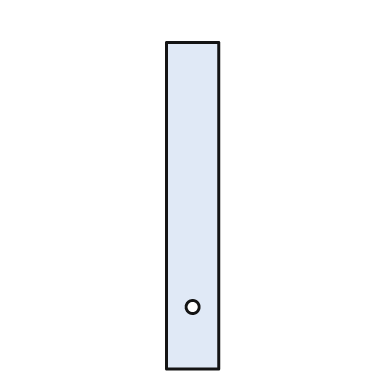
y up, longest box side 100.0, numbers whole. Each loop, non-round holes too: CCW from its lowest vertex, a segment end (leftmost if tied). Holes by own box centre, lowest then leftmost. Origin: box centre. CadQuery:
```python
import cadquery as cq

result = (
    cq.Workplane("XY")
    .moveTo(-8.0, -50.0)
    .lineTo(8.0, -50.0)
    .lineTo(8.0, 50.0)
    .lineTo(-8.0, 50.0)
    .close()
    .moveTo(0.0, -31.0)
    .circle(2.0)
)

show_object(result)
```